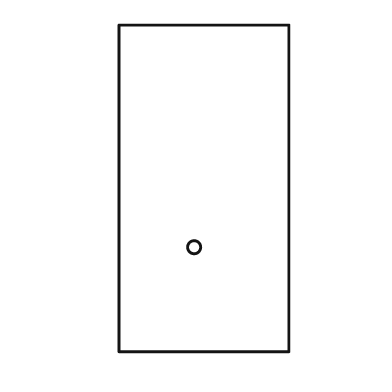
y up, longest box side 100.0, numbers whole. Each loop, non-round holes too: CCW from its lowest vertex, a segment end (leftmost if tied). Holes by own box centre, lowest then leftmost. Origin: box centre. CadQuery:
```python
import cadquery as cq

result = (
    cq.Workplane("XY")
    .moveTo(-26.0, -50.0)
    .lineTo(26.0, -50.0)
    .lineTo(26.0, 50.0)
    .lineTo(-26.0, 50.0)
    .close()
    .moveTo(-3.0, -18.0)
    .circle(2.0)
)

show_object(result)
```